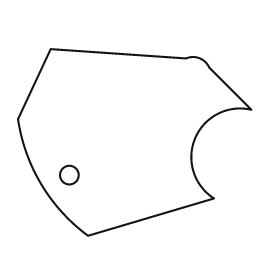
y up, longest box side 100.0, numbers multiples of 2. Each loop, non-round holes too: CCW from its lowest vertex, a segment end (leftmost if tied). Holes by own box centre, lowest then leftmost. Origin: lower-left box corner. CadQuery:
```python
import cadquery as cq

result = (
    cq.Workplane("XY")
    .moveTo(30.0, 0.0)
    .lineTo(84.0, 16.0)
    .threePointArc((76.0, 42.0), (100.0, 54.0))
    .lineTo(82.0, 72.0)
    .threePointArc((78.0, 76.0), (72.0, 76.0))
    .lineTo(14.0, 80.0)
    .lineTo(0.0, 50.0)
    .threePointArc((10.0, 22.0), (30.0, 0.0))
    .close()
    .moveTo(22.0, 26.0)
    .circle(4.0)
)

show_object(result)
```